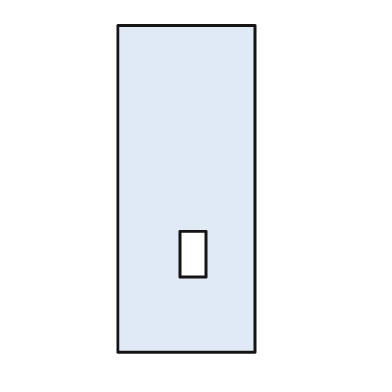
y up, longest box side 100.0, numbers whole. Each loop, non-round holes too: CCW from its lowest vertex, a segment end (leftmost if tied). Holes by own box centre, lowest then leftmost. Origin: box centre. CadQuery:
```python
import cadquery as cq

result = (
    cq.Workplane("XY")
    .moveTo(-21.0, -50.0)
    .lineTo(21.0, -50.0)
    .lineTo(21.0, 50.0)
    .lineTo(-21.0, 50.0)
    .close()
    .moveTo(-2.0, -27.0)
    .lineTo(6.0, -27.0)
    .lineTo(6.0, -13.0)
    .lineTo(-2.0, -13.0)
    .close()
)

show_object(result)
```